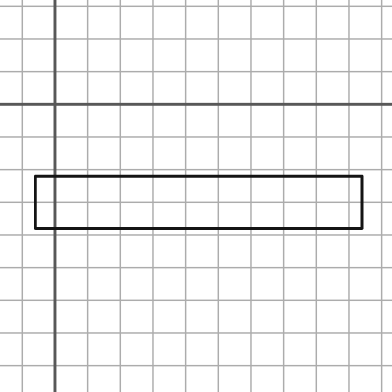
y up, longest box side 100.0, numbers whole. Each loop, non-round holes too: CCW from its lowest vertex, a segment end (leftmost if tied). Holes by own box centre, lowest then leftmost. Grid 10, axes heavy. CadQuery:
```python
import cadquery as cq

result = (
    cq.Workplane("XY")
    .moveTo(-6.0, -38.0)
    .lineTo(94.0, -38.0)
    .lineTo(94.0, -22.0)
    .lineTo(-6.0, -22.0)
    .close()
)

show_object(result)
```